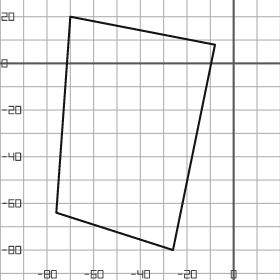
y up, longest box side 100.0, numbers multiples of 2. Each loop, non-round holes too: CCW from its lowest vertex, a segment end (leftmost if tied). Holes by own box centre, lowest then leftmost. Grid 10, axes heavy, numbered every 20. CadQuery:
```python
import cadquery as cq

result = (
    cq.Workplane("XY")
    .moveTo(-26.0, -80.0)
    .lineTo(-8.0, 8.0)
    .lineTo(-70.0, 20.0)
    .lineTo(-76.0, -64.0)
    .close()
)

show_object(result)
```